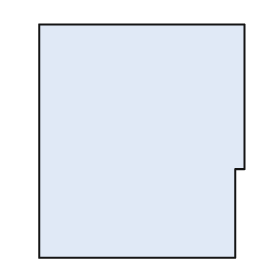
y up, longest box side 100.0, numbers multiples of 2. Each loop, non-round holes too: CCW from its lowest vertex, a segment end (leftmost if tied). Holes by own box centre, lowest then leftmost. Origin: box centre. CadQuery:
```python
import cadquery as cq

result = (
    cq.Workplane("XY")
    .moveTo(-44.0, -50.0)
    .lineTo(40.0, -50.0)
    .lineTo(40.0, -12.0)
    .lineTo(44.0, -12.0)
    .lineTo(44.0, 50.0)
    .lineTo(-44.0, 50.0)
    .close()
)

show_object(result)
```